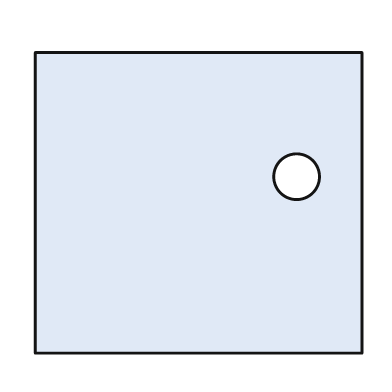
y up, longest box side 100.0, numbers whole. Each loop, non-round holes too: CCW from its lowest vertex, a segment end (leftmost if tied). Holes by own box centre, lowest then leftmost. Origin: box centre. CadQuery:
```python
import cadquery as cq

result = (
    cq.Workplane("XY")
    .moveTo(-50.0, -46.0)
    .lineTo(50.0, -46.0)
    .lineTo(50.0, 46.0)
    .lineTo(-50.0, 46.0)
    .close()
    .moveTo(30.0, 8.0)
    .circle(7.0)
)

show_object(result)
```